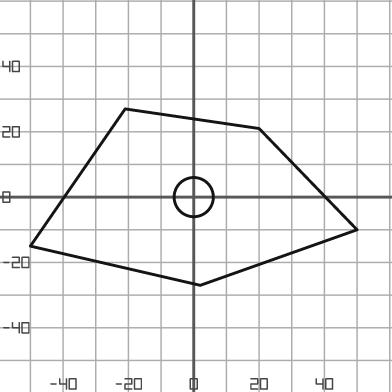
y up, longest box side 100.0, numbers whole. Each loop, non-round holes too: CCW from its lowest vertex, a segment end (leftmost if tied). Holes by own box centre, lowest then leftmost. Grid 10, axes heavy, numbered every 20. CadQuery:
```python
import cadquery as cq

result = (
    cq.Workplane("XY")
    .moveTo(2.0, -27.0)
    .lineTo(50.0, -10.0)
    .lineTo(20.0, 21.0)
    .lineTo(-21.0, 27.0)
    .lineTo(-50.0, -15.0)
    .close()
    .moveTo(0.0, 0.0)
    .circle(6.0)
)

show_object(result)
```